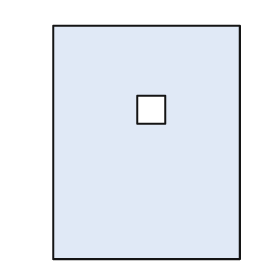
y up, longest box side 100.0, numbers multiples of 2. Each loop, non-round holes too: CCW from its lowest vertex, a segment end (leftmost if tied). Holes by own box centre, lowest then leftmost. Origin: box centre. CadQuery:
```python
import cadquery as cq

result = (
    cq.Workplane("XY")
    .moveTo(-40.0, -50.0)
    .lineTo(40.0, -50.0)
    .lineTo(40.0, 50.0)
    .lineTo(-40.0, 50.0)
    .close()
    .moveTo(-4.0, 8.0)
    .lineTo(8.0, 8.0)
    .lineTo(8.0, 20.0)
    .lineTo(-4.0, 20.0)
    .close()
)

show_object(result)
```